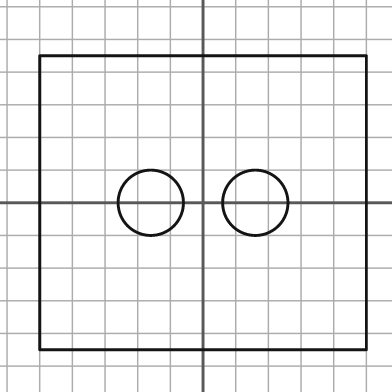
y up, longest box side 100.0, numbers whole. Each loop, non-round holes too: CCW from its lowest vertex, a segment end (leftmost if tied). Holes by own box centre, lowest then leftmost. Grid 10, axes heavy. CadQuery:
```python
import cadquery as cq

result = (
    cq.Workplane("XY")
    .moveTo(-50.0, -45.0)
    .lineTo(50.0, -45.0)
    .lineTo(50.0, 45.0)
    .lineTo(-50.0, 45.0)
    .close()
    .moveTo(-16.0, 0.0)
    .circle(10.0)
    .moveTo(16.0, 0.0)
    .circle(10.0)
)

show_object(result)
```